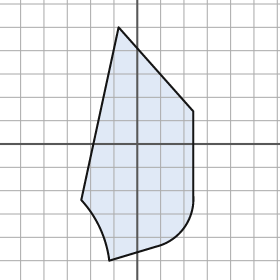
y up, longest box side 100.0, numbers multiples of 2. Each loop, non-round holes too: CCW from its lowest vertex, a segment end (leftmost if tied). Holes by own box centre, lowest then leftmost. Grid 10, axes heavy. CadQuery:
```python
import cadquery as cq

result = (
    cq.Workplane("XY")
    .moveTo(-12.0, -50.0)
    .lineTo(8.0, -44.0)
    .threePointArc((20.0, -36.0), (24.0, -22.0))
    .lineTo(24.0, 14.0)
    .lineTo(-8.0, 50.0)
    .lineTo(-24.0, -24.0)
    .threePointArc((-16.0, -36.0), (-12.0, -50.0))
    .close()
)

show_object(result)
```